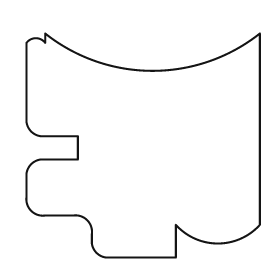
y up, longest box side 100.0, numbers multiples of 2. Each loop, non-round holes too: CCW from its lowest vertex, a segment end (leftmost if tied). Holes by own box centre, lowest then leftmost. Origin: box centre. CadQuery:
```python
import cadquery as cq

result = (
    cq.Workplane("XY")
    .moveTo(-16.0, -48.0)
    .lineTo(14.0, -48.0)
    .lineTo(14.0, -34.0)
    .threePointArc((32.0, -42.0), (50.0, -34.0))
    .lineTo(50.0, 48.0)
    .threePointArc((4.0, 32.0), (-42.0, 48.0))
    .lineTo(-42.0, 44.0)
    .threePointArc((-46.0, 46.0), (-50.0, 44.0))
    .lineTo(-50.0, 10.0)
    .threePointArc((-48.0, 6.0), (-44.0, 4.0))
    .lineTo(-28.0, 4.0)
    .lineTo(-28.0, -6.0)
    .lineTo(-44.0, -6.0)
    .threePointArc((-48.0, -8.0), (-50.0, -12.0))
    .lineTo(-50.0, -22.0)
    .threePointArc((-48.0, -28.0), (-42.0, -30.0))
    .lineTo(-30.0, -30.0)
    .threePointArc((-24.0, -32.0), (-22.0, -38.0))
    .lineTo(-22.0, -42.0)
    .threePointArc((-20.0, -46.0), (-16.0, -48.0))
    .close()
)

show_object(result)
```